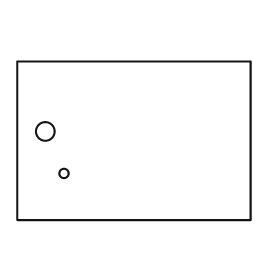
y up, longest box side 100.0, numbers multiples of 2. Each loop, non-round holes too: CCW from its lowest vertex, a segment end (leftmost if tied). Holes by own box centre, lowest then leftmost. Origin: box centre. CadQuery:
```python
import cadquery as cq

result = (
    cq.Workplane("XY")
    .moveTo(-50.0, -34.0)
    .lineTo(50.0, -34.0)
    .lineTo(50.0, 34.0)
    .lineTo(-50.0, 34.0)
    .close()
    .moveTo(-30.0, -14.0)
    .circle(2.0)
    .moveTo(-38.0, 4.0)
    .circle(4.0)
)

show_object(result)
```